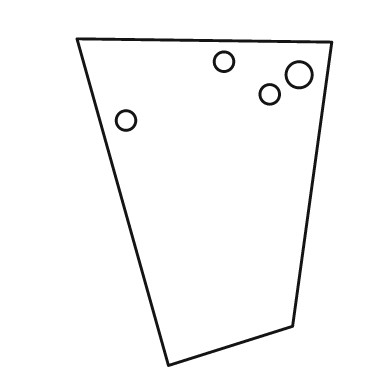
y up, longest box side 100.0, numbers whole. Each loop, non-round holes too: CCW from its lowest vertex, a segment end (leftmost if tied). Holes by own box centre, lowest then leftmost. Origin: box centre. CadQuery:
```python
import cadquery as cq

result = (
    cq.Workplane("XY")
    .moveTo(-11.0, -50.0)
    .lineTo(27.0, -38.0)
    .lineTo(39.0, 49.0)
    .lineTo(-39.0, 50.0)
    .close()
    .moveTo(-24.0, 25.0)
    .circle(3.0)
    .moveTo(20.0, 33.0)
    .circle(3.0)
    .moveTo(29.0, 39.0)
    .circle(4.0)
    .moveTo(6.0, 43.0)
    .circle(3.0)
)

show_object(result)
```